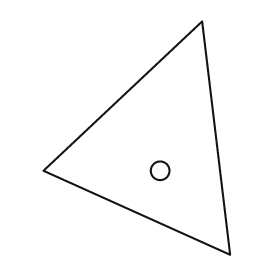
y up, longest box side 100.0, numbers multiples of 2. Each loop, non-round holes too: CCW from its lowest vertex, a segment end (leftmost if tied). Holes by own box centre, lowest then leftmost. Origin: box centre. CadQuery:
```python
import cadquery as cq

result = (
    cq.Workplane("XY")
    .moveTo(40.0, -50.0)
    .lineTo(28.0, 50.0)
    .lineTo(-40.0, -14.0)
    .close()
    .moveTo(10.0, -14.0)
    .circle(4.0)
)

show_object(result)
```